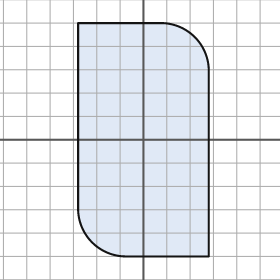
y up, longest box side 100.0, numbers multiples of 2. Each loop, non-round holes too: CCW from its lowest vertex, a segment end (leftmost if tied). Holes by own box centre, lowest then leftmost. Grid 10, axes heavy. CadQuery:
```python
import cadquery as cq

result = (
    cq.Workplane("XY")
    .moveTo(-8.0, -50.0)
    .lineTo(28.0, -50.0)
    .lineTo(28.0, 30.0)
    .threePointArc((22.0, 44.0), (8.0, 50.0))
    .lineTo(-28.0, 50.0)
    .lineTo(-28.0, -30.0)
    .threePointArc((-22.0, -44.0), (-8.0, -50.0))
    .close()
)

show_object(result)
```